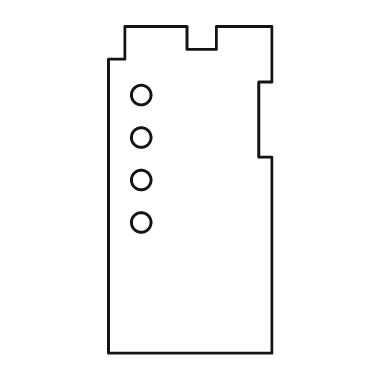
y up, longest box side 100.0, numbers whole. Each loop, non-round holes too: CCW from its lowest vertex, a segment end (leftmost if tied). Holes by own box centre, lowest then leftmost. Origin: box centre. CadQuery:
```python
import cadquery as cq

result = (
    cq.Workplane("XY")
    .moveTo(-25.0, -50.0)
    .lineTo(25.0, -50.0)
    .lineTo(25.0, 10.0)
    .lineTo(21.0, 10.0)
    .lineTo(21.0, 33.0)
    .lineTo(25.0, 33.0)
    .lineTo(25.0, 50.0)
    .lineTo(8.0, 50.0)
    .lineTo(8.0, 43.0)
    .lineTo(-1.0, 43.0)
    .lineTo(-1.0, 50.0)
    .lineTo(-20.0, 50.0)
    .lineTo(-20.0, 40.0)
    .lineTo(-25.0, 40.0)
    .close()
    .moveTo(-15.0, -10.0)
    .circle(3.0)
    .moveTo(-15.0, 3.0)
    .circle(3.0)
    .moveTo(-15.0, 16.0)
    .circle(3.0)
    .moveTo(-15.0, 29.0)
    .circle(3.0)
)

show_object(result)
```